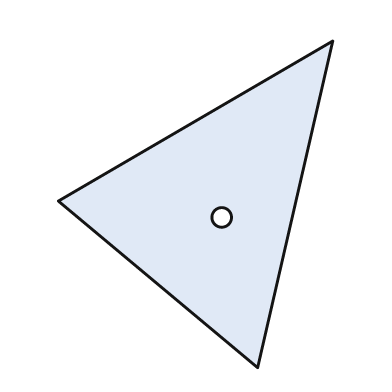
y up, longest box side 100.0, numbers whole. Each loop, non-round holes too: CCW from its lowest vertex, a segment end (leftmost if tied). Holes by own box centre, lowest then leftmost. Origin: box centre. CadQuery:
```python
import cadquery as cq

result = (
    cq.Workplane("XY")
    .moveTo(19.0, -50.0)
    .lineTo(42.0, 50.0)
    .lineTo(-42.0, 1.0)
    .close()
    .moveTo(8.0, -4.0)
    .circle(3.0)
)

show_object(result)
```